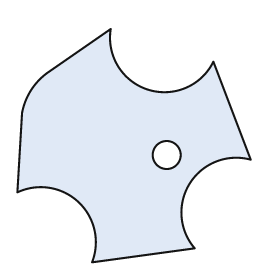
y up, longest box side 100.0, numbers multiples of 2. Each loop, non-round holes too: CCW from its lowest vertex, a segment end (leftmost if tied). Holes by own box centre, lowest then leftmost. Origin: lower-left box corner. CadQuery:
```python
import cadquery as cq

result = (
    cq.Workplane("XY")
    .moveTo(32.0, 0.0)
    .lineTo(76.0, 6.0)
    .threePointArc((74.0, 34.0), (100.0, 44.0))
    .lineTo(84.0, 86.0)
    .threePointArc((56.0, 74.0), (40.0, 100.0))
    .lineTo(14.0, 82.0)
    .threePointArc((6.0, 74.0), (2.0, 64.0))
    .lineTo(0.0, 30.0)
    .threePointArc((26.0, 26.0), (32.0, 0.0))
    .close()
    .moveTo(64.0, 46.0)
    .circle(6.0)
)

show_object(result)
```